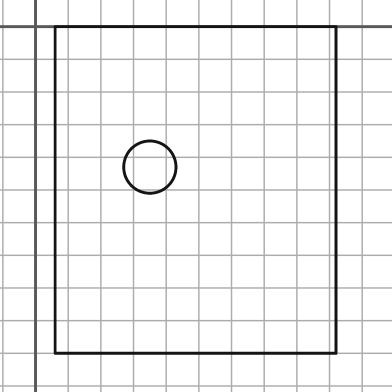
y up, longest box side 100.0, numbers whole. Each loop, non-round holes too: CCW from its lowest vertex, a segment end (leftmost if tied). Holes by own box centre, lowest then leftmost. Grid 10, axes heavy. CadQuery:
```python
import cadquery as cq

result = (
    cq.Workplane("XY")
    .moveTo(6.0, -100.0)
    .lineTo(92.0, -100.0)
    .lineTo(92.0, 0.0)
    .lineTo(6.0, 0.0)
    .close()
    .moveTo(35.0, -43.0)
    .circle(8.0)
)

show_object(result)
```